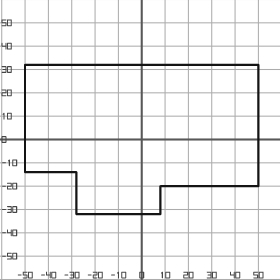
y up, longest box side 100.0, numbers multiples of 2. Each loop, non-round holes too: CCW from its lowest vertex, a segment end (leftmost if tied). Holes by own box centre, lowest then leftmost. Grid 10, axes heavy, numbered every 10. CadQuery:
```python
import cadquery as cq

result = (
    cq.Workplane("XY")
    .moveTo(-28.0, -32.0)
    .lineTo(8.0, -32.0)
    .lineTo(8.0, -20.0)
    .lineTo(50.0, -20.0)
    .lineTo(50.0, 32.0)
    .lineTo(-50.0, 32.0)
    .lineTo(-50.0, -14.0)
    .lineTo(-28.0, -14.0)
    .close()
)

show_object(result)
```